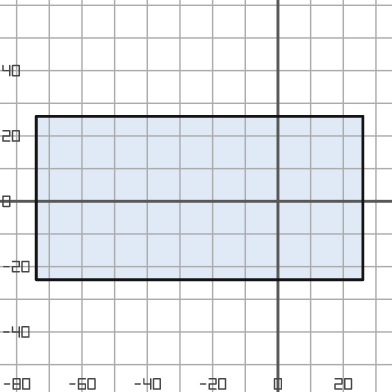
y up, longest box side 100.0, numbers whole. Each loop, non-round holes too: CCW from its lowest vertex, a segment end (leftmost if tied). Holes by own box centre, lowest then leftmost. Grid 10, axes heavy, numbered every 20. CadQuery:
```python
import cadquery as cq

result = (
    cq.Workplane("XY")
    .moveTo(-74.0, -24.0)
    .lineTo(26.0, -24.0)
    .lineTo(26.0, 26.0)
    .lineTo(-74.0, 26.0)
    .close()
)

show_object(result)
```